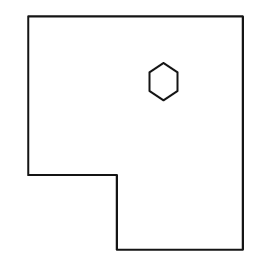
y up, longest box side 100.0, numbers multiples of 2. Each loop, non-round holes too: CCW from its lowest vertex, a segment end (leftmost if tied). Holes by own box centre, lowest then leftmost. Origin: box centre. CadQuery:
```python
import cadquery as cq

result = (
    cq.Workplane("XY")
    .moveTo(-8.0, -50.0)
    .lineTo(46.0, -50.0)
    .lineTo(46.0, 50.0)
    .lineTo(-46.0, 50.0)
    .lineTo(-46.0, -18.0)
    .lineTo(-8.0, -18.0)
    .close()
    .moveTo(12.0, 14.0)
    .lineTo(18.0, 18.0)
    .lineTo(18.0, 26.0)
    .lineTo(12.0, 30.0)
    .lineTo(6.0, 26.0)
    .lineTo(6.0, 18.0)
    .close()
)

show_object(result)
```